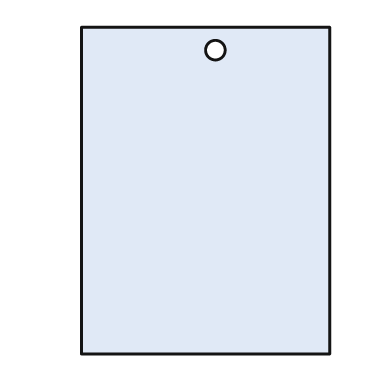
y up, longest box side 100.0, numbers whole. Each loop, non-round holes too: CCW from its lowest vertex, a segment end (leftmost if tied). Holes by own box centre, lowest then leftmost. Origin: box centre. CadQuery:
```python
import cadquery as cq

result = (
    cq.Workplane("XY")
    .moveTo(-38.0, -50.0)
    .lineTo(38.0, -50.0)
    .lineTo(38.0, 50.0)
    .lineTo(-38.0, 50.0)
    .close()
    .moveTo(3.0, 43.0)
    .circle(3.0)
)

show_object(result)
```